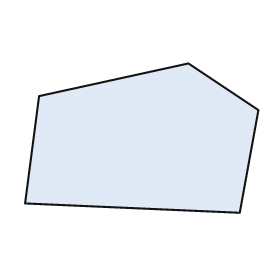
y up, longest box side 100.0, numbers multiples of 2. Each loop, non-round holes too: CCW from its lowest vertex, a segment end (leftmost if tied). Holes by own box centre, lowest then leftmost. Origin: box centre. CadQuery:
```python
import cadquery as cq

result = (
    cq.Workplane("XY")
    .moveTo(42.0, -32.0)
    .lineTo(50.0, 12.0)
    .lineTo(20.0, 32.0)
    .lineTo(-44.0, 18.0)
    .lineTo(-50.0, -28.0)
    .close()
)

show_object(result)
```